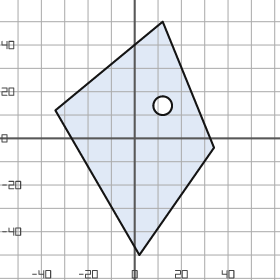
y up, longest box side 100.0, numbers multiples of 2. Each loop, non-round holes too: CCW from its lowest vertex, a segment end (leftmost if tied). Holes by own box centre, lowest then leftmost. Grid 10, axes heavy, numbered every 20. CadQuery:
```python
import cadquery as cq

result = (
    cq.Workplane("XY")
    .moveTo(2.0, -50.0)
    .lineTo(34.0, -4.0)
    .lineTo(12.0, 50.0)
    .lineTo(-34.0, 12.0)
    .close()
    .moveTo(12.0, 14.0)
    .circle(4.0)
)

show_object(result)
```